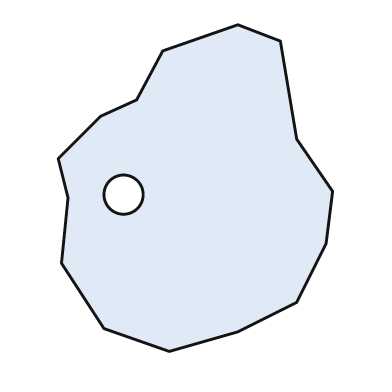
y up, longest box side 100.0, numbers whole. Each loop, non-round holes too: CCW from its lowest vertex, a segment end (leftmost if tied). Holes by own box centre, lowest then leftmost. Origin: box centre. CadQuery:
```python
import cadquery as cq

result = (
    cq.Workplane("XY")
    .moveTo(-8.0, -50.0)
    .lineTo(13.0, -44.0)
    .lineTo(31.0, -35.0)
    .lineTo(40.0, -17.0)
    .lineTo(42.0, -1.0)
    .lineTo(31.0, 15.0)
    .lineTo(26.0, 45.0)
    .lineTo(13.0, 50.0)
    .lineTo(-10.0, 42.0)
    .lineTo(-18.0, 27.0)
    .lineTo(-29.0, 22.0)
    .lineTo(-42.0, 9.0)
    .lineTo(-39.0, -3.0)
    .lineTo(-41.0, -23.0)
    .lineTo(-28.0, -43.0)
    .close()
    .moveTo(-22.0, -2.0)
    .circle(6.0)
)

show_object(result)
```